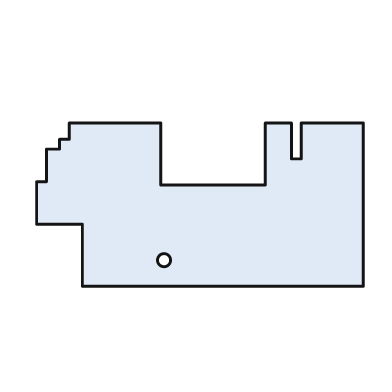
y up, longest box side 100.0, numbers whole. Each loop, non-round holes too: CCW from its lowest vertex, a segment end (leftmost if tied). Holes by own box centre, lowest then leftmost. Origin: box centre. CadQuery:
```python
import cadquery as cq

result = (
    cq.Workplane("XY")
    .moveTo(-36.0, -25.0)
    .lineTo(50.0, -25.0)
    .lineTo(50.0, 25.0)
    .lineTo(31.0, 25.0)
    .lineTo(31.0, 14.0)
    .lineTo(28.0, 14.0)
    .lineTo(28.0, 25.0)
    .lineTo(20.0, 25.0)
    .lineTo(20.0, 6.0)
    .lineTo(-12.0, 6.0)
    .lineTo(-12.0, 25.0)
    .lineTo(-40.0, 25.0)
    .lineTo(-40.0, 20.0)
    .lineTo(-43.0, 20.0)
    .lineTo(-43.0, 17.0)
    .lineTo(-47.0, 17.0)
    .lineTo(-47.0, 7.0)
    .lineTo(-50.0, 7.0)
    .lineTo(-50.0, -6.0)
    .lineTo(-36.0, -6.0)
    .close()
    .moveTo(-11.0, -17.0)
    .circle(2.0)
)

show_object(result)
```